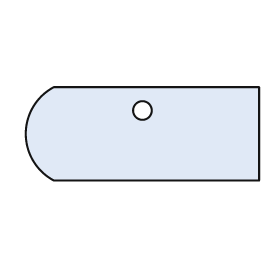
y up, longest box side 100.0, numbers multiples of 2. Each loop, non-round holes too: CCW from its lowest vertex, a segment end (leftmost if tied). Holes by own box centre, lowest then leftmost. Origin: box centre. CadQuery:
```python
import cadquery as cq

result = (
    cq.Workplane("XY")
    .moveTo(-38.0, -20.0)
    .lineTo(50.0, -20.0)
    .lineTo(50.0, 20.0)
    .lineTo(-38.0, 20.0)
    .threePointArc((-50.0, 0.0), (-38.0, -20.0))
    .close()
    .moveTo(0.0, 10.0)
    .circle(4.0)
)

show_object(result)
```